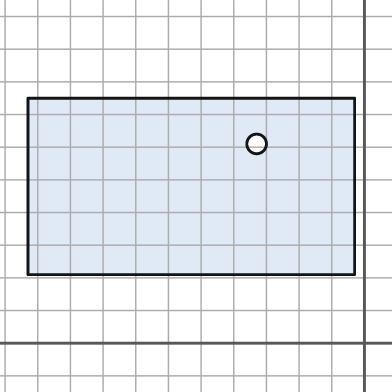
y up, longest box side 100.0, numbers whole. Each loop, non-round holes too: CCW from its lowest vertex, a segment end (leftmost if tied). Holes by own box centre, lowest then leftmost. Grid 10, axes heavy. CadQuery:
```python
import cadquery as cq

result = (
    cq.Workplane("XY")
    .moveTo(-103.0, 21.0)
    .lineTo(-3.0, 21.0)
    .lineTo(-3.0, 75.0)
    .lineTo(-103.0, 75.0)
    .close()
    .moveTo(-33.0, 61.0)
    .circle(3.0)
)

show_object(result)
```